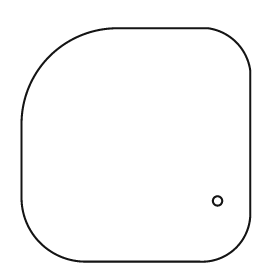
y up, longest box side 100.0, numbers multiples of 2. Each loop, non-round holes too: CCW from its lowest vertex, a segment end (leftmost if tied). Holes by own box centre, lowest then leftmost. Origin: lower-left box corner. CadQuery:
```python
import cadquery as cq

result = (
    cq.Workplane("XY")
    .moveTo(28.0, 0.0)
    .lineTo(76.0, 0.0)
    .threePointArc((92.0, 6.0), (98.0, 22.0))
    .lineTo(98.0, 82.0)
    .threePointArc((92.0, 94.0), (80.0, 100.0))
    .lineTo(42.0, 100.0)
    .threePointArc((12.0, 88.0), (0.0, 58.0))
    .lineTo(0.0, 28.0)
    .threePointArc((8.0, 8.0), (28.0, 0.0))
    .close()
    .moveTo(84.0, 26.0)
    .circle(2.0)
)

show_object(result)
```